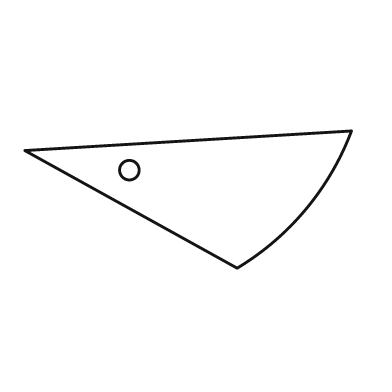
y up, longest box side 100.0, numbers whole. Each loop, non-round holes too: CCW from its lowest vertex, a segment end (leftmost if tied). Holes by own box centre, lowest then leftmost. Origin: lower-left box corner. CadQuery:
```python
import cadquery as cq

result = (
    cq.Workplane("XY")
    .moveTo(65.0, 0.0)
    .threePointArc((86.0, 18.0), (100.0, 42.0))
    .lineTo(0.0, 36.0)
    .close()
    .moveTo(32.0, 30.0)
    .circle(3.0)
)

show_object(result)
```